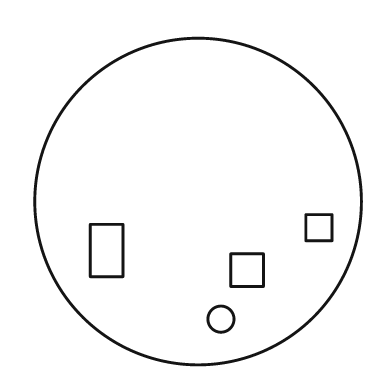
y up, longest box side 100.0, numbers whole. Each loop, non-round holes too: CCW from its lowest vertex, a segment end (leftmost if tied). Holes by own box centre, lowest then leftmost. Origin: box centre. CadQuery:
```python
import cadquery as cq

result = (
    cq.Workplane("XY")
    .moveTo(0.0, 0.0)
    .circle(50.0)
    .moveTo(7.0, -36.0)
    .circle(4.0)
    .moveTo(10.0, -26.0)
    .lineTo(20.0, -26.0)
    .lineTo(20.0, -16.0)
    .lineTo(10.0, -16.0)
    .close()
    .moveTo(-33.0, -23.0)
    .lineTo(-23.0, -23.0)
    .lineTo(-23.0, -7.0)
    .lineTo(-33.0, -7.0)
    .close()
    .moveTo(33.0, -12.0)
    .lineTo(41.0, -12.0)
    .lineTo(41.0, -4.0)
    .lineTo(33.0, -4.0)
    .close()
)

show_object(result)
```